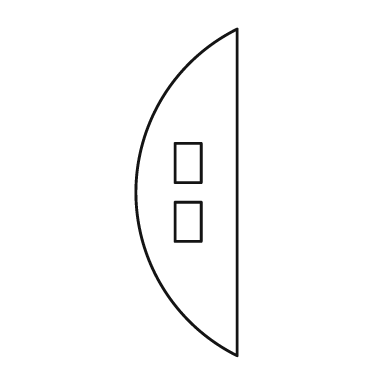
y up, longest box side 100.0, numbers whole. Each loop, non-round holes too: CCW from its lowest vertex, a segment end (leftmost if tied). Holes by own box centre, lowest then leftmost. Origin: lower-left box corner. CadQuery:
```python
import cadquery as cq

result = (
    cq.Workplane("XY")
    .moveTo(31.0, 0.0)
    .lineTo(31.0, 100.0)
    .threePointArc((0.0, 50.0), (31.0, 0.0))
    .close()
    .moveTo(12.0, 35.0)
    .lineTo(20.0, 35.0)
    .lineTo(20.0, 47.0)
    .lineTo(12.0, 47.0)
    .close()
    .moveTo(12.0, 53.0)
    .lineTo(20.0, 53.0)
    .lineTo(20.0, 65.0)
    .lineTo(12.0, 65.0)
    .close()
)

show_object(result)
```